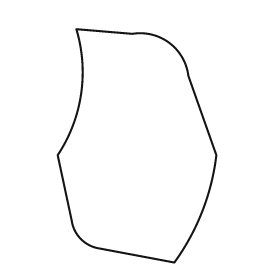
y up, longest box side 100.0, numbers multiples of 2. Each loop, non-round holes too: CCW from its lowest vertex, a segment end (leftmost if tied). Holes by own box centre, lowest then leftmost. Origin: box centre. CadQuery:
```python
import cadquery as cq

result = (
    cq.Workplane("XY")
    .moveTo(16.0, -50.0)
    .threePointArc((28.0, -28.0), (34.0, -4.0))
    .lineTo(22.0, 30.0)
    .threePointArc((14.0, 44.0), (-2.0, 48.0))
    .lineTo(-26.0, 50.0)
    .threePointArc((-24.0, 22.0), (-34.0, -4.0))
    .lineTo(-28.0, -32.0)
    .threePointArc((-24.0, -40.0), (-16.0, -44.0))
    .close()
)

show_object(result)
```